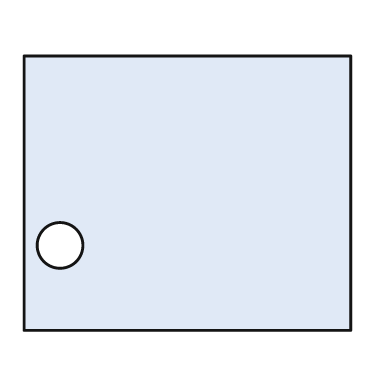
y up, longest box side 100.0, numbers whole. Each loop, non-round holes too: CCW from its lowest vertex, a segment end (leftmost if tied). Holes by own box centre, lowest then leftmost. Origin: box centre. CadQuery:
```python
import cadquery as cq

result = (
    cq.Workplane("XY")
    .moveTo(-50.0, -42.0)
    .lineTo(50.0, -42.0)
    .lineTo(50.0, 42.0)
    .lineTo(-50.0, 42.0)
    .close()
    .moveTo(-39.0, -16.0)
    .circle(7.0)
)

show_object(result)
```